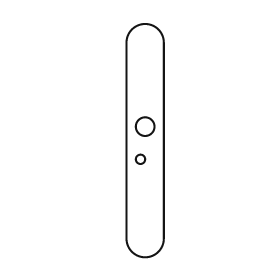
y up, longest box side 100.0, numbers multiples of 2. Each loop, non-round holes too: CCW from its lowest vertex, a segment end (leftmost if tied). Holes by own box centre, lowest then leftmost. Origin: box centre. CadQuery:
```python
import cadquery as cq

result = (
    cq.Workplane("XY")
    .moveTo(-8.0, -42.0)
    .threePointArc((0.0, -50.0), (8.0, -42.0))
    .lineTo(8.0, 42.0)
    .threePointArc((0.0, 50.0), (-8.0, 42.0))
    .close()
    .moveTo(-2.0, -8.0)
    .circle(2.0)
    .moveTo(0.0, 6.0)
    .circle(4.0)
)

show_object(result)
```